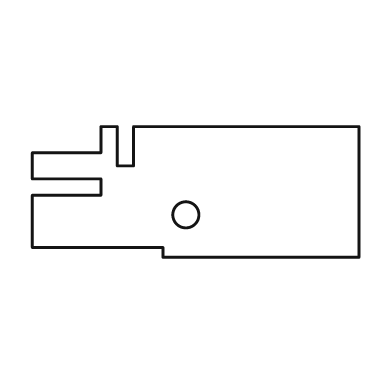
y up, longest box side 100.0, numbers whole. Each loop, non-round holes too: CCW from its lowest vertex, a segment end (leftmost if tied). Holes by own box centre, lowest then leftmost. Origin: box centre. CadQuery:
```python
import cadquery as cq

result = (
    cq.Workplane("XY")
    .moveTo(-10.0, -20.0)
    .lineTo(50.0, -20.0)
    .lineTo(50.0, 20.0)
    .lineTo(-19.0, 20.0)
    .lineTo(-19.0, 8.0)
    .lineTo(-24.0, 8.0)
    .lineTo(-24.0, 20.0)
    .lineTo(-29.0, 20.0)
    .lineTo(-29.0, 12.0)
    .lineTo(-50.0, 12.0)
    .lineTo(-50.0, 4.0)
    .lineTo(-29.0, 4.0)
    .lineTo(-29.0, -1.0)
    .lineTo(-50.0, -1.0)
    .lineTo(-50.0, -17.0)
    .lineTo(-10.0, -17.0)
    .close()
    .moveTo(-3.0, -7.0)
    .circle(4.0)
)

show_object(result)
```